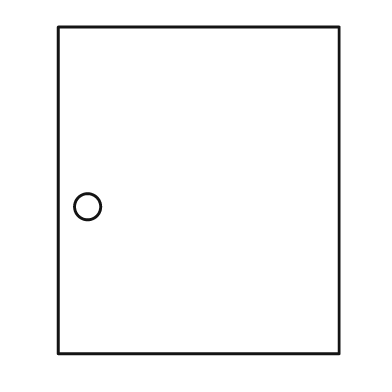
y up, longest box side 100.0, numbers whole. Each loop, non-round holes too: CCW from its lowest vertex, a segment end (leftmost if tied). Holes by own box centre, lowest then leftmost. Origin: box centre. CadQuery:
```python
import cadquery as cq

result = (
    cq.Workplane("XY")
    .moveTo(-43.0, -50.0)
    .lineTo(43.0, -50.0)
    .lineTo(43.0, 50.0)
    .lineTo(-43.0, 50.0)
    .close()
    .moveTo(-34.0, -5.0)
    .circle(4.0)
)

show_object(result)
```